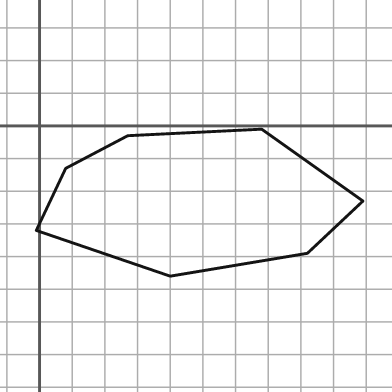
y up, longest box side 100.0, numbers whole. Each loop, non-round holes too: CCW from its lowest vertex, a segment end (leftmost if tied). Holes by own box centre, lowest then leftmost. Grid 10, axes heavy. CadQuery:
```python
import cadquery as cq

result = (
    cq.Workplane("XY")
    .moveTo(40.0, -46.0)
    .lineTo(82.0, -39.0)
    .lineTo(99.0, -23.0)
    .lineTo(68.0, -1.0)
    .lineTo(27.0, -3.0)
    .lineTo(8.0, -13.0)
    .lineTo(-1.0, -32.0)
    .close()
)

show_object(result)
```